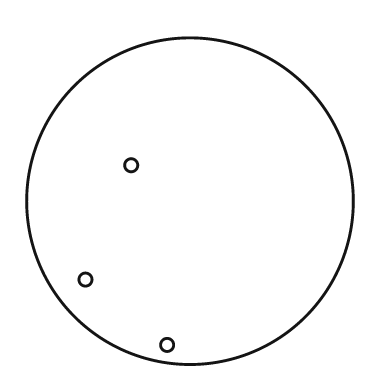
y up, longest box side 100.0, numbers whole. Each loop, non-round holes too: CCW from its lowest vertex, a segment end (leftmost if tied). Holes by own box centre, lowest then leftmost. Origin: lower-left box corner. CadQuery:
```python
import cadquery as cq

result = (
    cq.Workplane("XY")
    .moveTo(50.0, 50.0)
    .circle(50.0)
    .moveTo(43.0, 6.0)
    .circle(2.0)
    .moveTo(18.0, 26.0)
    .circle(2.0)
    .moveTo(32.0, 61.0)
    .circle(2.0)
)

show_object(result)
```